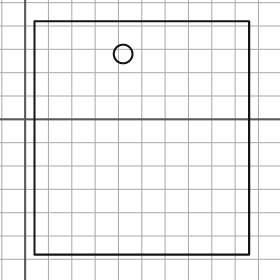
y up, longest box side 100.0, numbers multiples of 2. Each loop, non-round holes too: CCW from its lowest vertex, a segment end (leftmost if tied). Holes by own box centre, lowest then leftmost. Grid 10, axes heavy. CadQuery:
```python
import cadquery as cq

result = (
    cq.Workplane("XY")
    .moveTo(4.0, -58.0)
    .lineTo(96.0, -58.0)
    .lineTo(96.0, 42.0)
    .lineTo(4.0, 42.0)
    .close()
    .moveTo(42.0, 28.0)
    .circle(4.0)
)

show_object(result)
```